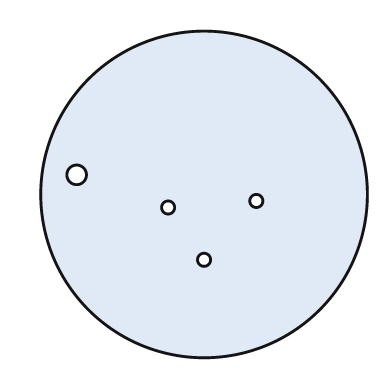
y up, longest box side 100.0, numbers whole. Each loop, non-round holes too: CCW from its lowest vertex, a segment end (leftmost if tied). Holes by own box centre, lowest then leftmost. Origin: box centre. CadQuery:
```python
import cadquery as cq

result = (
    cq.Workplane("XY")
    .moveTo(0.0, 0.0)
    .circle(50.0)
    .moveTo(0.0, -20.0)
    .circle(2.0)
    .moveTo(-11.0, -4.0)
    .circle(2.0)
    .moveTo(16.0, -2.0)
    .circle(2.0)
    .moveTo(-39.0, 6.0)
    .circle(3.0)
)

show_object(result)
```